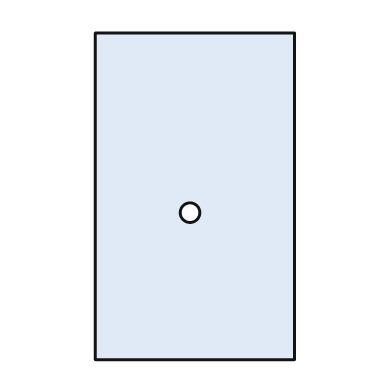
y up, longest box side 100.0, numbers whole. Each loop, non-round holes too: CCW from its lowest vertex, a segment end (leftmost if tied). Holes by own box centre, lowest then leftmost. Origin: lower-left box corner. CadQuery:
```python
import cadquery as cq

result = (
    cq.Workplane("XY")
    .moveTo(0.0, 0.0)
    .lineTo(61.0, 0.0)
    .lineTo(61.0, 100.0)
    .lineTo(0.0, 100.0)
    .close()
    .moveTo(29.0, 45.0)
    .circle(3.0)
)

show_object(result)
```